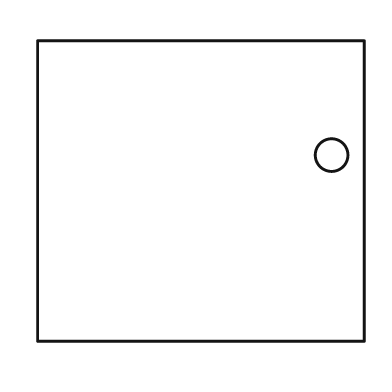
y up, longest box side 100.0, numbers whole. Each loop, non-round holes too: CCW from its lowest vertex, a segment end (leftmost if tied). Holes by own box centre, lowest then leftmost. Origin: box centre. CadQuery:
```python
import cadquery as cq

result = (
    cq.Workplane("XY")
    .moveTo(-50.0, -46.0)
    .lineTo(50.0, -46.0)
    .lineTo(50.0, 46.0)
    .lineTo(-50.0, 46.0)
    .close()
    .moveTo(40.0, 11.0)
    .circle(5.0)
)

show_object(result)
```